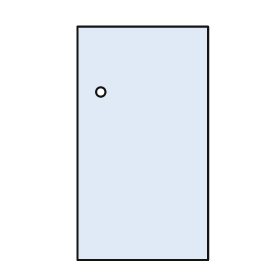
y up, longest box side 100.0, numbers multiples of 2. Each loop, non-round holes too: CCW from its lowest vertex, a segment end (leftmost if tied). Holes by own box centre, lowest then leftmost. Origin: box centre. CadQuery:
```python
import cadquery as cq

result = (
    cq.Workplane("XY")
    .moveTo(-28.0, -50.0)
    .lineTo(28.0, -50.0)
    .lineTo(28.0, 50.0)
    .lineTo(-28.0, 50.0)
    .close()
    .moveTo(-18.0, 22.0)
    .circle(2.0)
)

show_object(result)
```